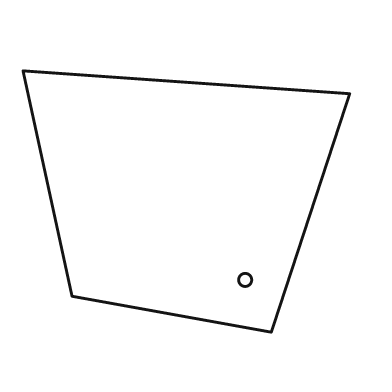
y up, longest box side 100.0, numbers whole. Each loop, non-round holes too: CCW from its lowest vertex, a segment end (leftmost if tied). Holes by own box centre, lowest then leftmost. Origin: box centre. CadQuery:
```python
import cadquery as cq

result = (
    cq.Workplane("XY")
    .moveTo(26.0, -40.0)
    .lineTo(50.0, 33.0)
    .lineTo(-50.0, 40.0)
    .lineTo(-35.0, -29.0)
    .close()
    .moveTo(18.0, -24.0)
    .circle(2.0)
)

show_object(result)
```